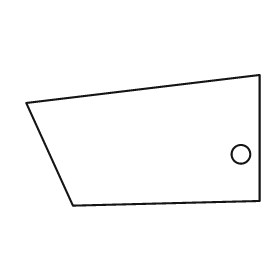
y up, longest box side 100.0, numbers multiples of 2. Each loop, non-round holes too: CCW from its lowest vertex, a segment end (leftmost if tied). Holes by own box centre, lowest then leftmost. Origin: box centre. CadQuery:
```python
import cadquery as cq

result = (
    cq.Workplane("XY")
    .moveTo(-30.0, -28.0)
    .lineTo(50.0, -26.0)
    .lineTo(50.0, 28.0)
    .lineTo(-50.0, 16.0)
    .close()
    .moveTo(42.0, -6.0)
    .circle(4.0)
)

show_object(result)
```